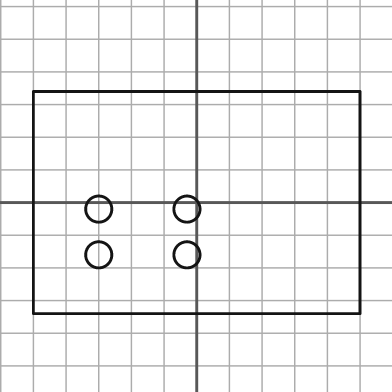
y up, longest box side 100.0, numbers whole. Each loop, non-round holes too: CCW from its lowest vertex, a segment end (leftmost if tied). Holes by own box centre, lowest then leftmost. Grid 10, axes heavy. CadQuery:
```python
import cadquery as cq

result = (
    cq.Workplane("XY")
    .moveTo(-50.0, -34.0)
    .lineTo(50.0, -34.0)
    .lineTo(50.0, 34.0)
    .lineTo(-50.0, 34.0)
    .close()
    .moveTo(-30.0, -16.0)
    .circle(4.0)
    .moveTo(-3.0, -16.0)
    .circle(4.0)
    .moveTo(-30.0, -2.0)
    .circle(4.0)
    .moveTo(-3.0, -2.0)
    .circle(4.0)
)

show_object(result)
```